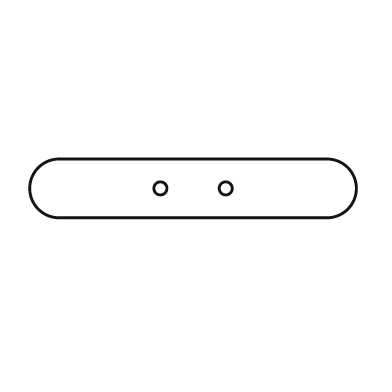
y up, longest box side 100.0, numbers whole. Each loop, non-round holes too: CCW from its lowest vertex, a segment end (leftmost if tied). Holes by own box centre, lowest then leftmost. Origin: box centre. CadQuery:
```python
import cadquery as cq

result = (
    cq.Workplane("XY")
    .moveTo(-41.0, -9.0)
    .lineTo(41.0, -9.0)
    .threePointArc((50.0, 0.0), (41.0, 9.0))
    .lineTo(-41.0, 9.0)
    .threePointArc((-50.0, 0.0), (-41.0, -9.0))
    .close()
    .moveTo(-10.0, 0.0)
    .circle(2.0)
    .moveTo(10.0, 0.0)
    .circle(2.0)
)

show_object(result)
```